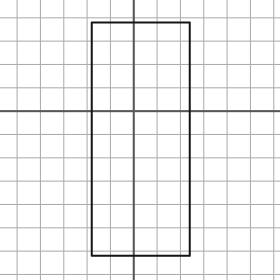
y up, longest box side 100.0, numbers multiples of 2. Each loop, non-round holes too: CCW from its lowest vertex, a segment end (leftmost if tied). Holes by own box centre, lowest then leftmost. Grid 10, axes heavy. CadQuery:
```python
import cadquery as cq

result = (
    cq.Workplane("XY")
    .moveTo(-18.0, -62.0)
    .lineTo(24.0, -62.0)
    .lineTo(24.0, 38.0)
    .lineTo(-18.0, 38.0)
    .close()
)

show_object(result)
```